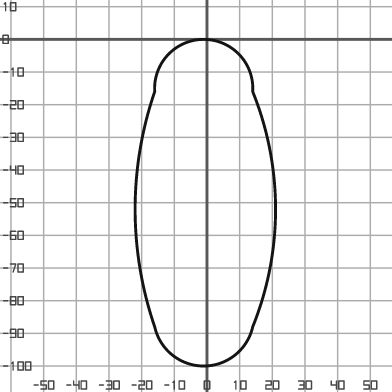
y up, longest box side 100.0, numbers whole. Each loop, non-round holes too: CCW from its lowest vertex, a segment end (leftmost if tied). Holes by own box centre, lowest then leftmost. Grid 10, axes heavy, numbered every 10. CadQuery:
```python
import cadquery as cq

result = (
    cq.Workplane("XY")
    .moveTo(-16.0, -88.0)
    .threePointArc((-1.0, -100.0), (14.0, -88.0))
    .threePointArc((21.0, -52.0), (14.0, -16.0))
    .threePointArc((-1.0, 0.0), (-16.0, -16.0))
    .threePointArc((-22.0, -52.0), (-16.0, -88.0))
    .close()
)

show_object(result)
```